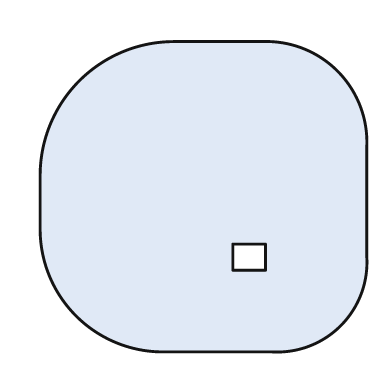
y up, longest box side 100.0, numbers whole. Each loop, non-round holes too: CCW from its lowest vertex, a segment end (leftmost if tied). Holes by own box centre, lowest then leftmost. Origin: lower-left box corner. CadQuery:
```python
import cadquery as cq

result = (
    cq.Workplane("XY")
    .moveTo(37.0, 0.0)
    .lineTo(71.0, 0.0)
    .threePointArc((92.0, 8.0), (100.0, 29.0))
    .lineTo(100.0, 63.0)
    .threePointArc((91.0, 86.0), (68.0, 95.0))
    .lineTo(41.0, 95.0)
    .threePointArc((12.0, 83.0), (0.0, 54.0))
    .lineTo(0.0, 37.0)
    .threePointArc((11.0, 11.0), (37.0, 0.0))
    .close()
    .moveTo(59.0, 25.0)
    .lineTo(69.0, 25.0)
    .lineTo(69.0, 33.0)
    .lineTo(59.0, 33.0)
    .close()
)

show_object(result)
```